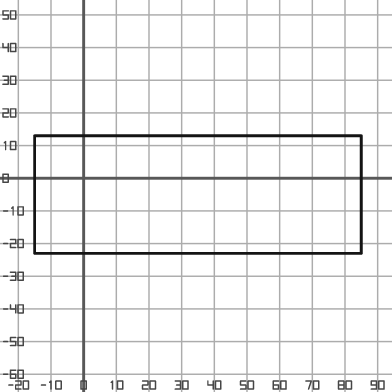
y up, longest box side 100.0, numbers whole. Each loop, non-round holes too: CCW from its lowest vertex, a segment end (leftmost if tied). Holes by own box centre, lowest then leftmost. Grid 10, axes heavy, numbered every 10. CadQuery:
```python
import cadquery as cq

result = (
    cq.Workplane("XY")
    .moveTo(-15.0, -23.0)
    .lineTo(85.0, -23.0)
    .lineTo(85.0, 13.0)
    .lineTo(-15.0, 13.0)
    .close()
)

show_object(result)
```